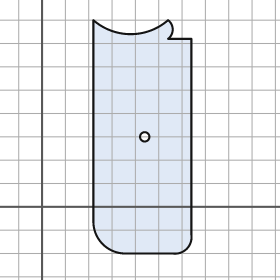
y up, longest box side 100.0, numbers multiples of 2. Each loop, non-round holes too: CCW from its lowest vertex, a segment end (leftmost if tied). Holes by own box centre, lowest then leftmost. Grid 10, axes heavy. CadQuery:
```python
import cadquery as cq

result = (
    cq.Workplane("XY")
    .moveTo(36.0, -20.0)
    .lineTo(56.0, -20.0)
    .threePointArc((62.0, -18.0), (64.0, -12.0))
    .lineTo(64.0, 72.0)
    .lineTo(54.0, 72.0)
    .threePointArc((56.0, 76.0), (54.0, 80.0))
    .threePointArc((38.0, 74.0), (22.0, 80.0))
    .lineTo(22.0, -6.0)
    .threePointArc((26.0, -16.0), (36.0, -20.0))
    .close()
    .moveTo(44.0, 30.0)
    .circle(2.0)
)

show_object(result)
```